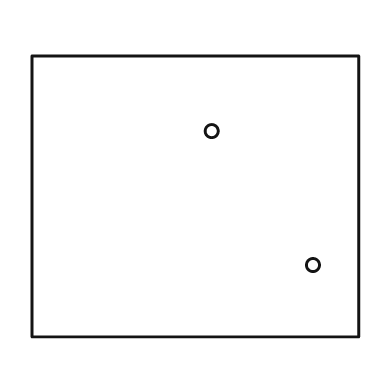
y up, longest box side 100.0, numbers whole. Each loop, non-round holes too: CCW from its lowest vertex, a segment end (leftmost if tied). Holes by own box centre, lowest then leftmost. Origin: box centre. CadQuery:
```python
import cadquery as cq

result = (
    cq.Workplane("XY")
    .moveTo(-50.0, -43.0)
    .lineTo(50.0, -43.0)
    .lineTo(50.0, 43.0)
    .lineTo(-50.0, 43.0)
    .close()
    .moveTo(36.0, -21.0)
    .circle(2.0)
    .moveTo(5.0, 20.0)
    .circle(2.0)
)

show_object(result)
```